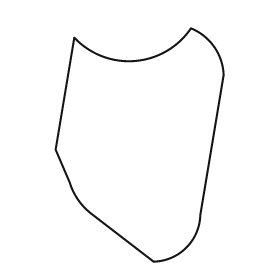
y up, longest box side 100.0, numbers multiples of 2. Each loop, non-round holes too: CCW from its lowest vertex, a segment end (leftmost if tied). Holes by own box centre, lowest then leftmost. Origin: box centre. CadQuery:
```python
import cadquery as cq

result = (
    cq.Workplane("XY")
    .moveTo(6.0, -50.0)
    .threePointArc((20.0, -44.0), (26.0, -30.0))
    .lineTo(36.0, 30.0)
    .threePointArc((32.0, 42.0), (22.0, 50.0))
    .threePointArc((-2.0, 36.0), (-28.0, 46.0))
    .lineTo(-36.0, -2.0)
    .lineTo(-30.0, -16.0)
    .threePointArc((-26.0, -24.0), (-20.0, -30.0))
    .close()
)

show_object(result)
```